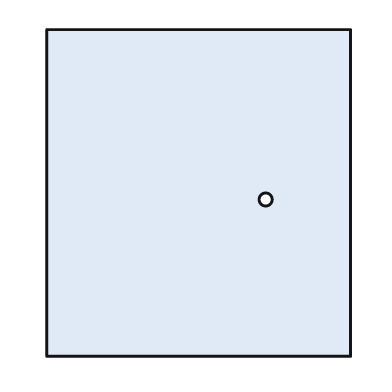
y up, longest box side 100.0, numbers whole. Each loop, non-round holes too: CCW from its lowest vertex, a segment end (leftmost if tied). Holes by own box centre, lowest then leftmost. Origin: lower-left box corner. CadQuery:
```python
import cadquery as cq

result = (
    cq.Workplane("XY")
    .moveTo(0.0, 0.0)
    .lineTo(93.0, 0.0)
    .lineTo(93.0, 100.0)
    .lineTo(0.0, 100.0)
    .close()
    .moveTo(67.0, 48.0)
    .circle(2.0)
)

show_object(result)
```